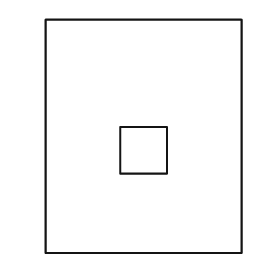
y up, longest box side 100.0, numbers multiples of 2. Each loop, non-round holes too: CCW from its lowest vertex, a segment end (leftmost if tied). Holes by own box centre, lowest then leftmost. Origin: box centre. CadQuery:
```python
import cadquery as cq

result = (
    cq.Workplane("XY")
    .moveTo(-42.0, -50.0)
    .lineTo(42.0, -50.0)
    .lineTo(42.0, 50.0)
    .lineTo(-42.0, 50.0)
    .close()
    .moveTo(-10.0, -16.0)
    .lineTo(10.0, -16.0)
    .lineTo(10.0, 4.0)
    .lineTo(-10.0, 4.0)
    .close()
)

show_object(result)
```